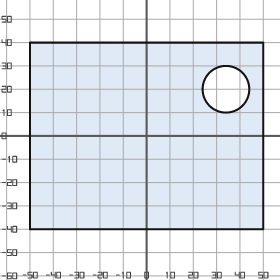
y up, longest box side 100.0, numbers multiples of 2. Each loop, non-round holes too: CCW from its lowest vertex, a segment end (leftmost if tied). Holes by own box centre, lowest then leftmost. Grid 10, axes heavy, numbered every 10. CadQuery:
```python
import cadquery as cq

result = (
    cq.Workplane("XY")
    .moveTo(-50.0, -40.0)
    .lineTo(50.0, -40.0)
    .lineTo(50.0, 40.0)
    .lineTo(-50.0, 40.0)
    .close()
    .moveTo(34.0, 20.0)
    .circle(10.0)
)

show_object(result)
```